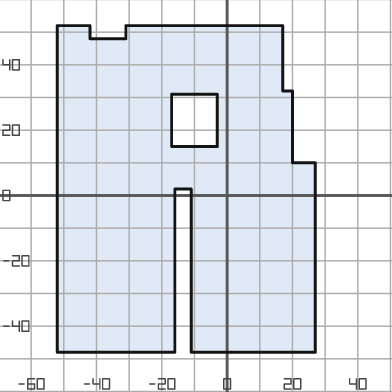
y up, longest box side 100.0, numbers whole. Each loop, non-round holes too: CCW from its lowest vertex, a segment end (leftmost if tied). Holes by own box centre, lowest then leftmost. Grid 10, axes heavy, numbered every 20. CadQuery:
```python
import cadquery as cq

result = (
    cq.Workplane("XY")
    .moveTo(-52.0, -48.0)
    .lineTo(-16.0, -48.0)
    .lineTo(-16.0, 2.0)
    .lineTo(-11.0, 2.0)
    .lineTo(-11.0, -48.0)
    .lineTo(27.0, -48.0)
    .lineTo(27.0, 10.0)
    .lineTo(20.0, 10.0)
    .lineTo(20.0, 32.0)
    .lineTo(17.0, 32.0)
    .lineTo(17.0, 52.0)
    .lineTo(-31.0, 52.0)
    .lineTo(-31.0, 48.0)
    .lineTo(-42.0, 48.0)
    .lineTo(-42.0, 52.0)
    .lineTo(-52.0, 52.0)
    .close()
    .moveTo(-17.0, 15.0)
    .lineTo(-3.0, 15.0)
    .lineTo(-3.0, 31.0)
    .lineTo(-17.0, 31.0)
    .close()
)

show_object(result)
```